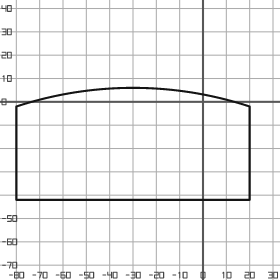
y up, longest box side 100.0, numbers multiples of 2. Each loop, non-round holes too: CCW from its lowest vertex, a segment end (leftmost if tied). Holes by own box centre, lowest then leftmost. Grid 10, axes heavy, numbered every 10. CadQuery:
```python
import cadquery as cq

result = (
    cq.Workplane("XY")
    .moveTo(-80.0, -42.0)
    .lineTo(20.0, -42.0)
    .lineTo(20.0, -2.0)
    .threePointArc((-30.0, 6.0), (-80.0, -2.0))
    .close()
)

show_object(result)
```